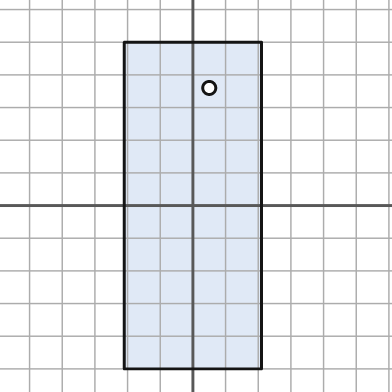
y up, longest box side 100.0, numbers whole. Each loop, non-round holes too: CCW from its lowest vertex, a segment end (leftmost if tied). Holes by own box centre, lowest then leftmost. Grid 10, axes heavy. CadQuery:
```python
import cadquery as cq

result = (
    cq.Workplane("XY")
    .moveTo(-21.0, -50.0)
    .lineTo(21.0, -50.0)
    .lineTo(21.0, 50.0)
    .lineTo(-21.0, 50.0)
    .close()
    .moveTo(5.0, 36.0)
    .circle(2.0)
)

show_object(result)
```